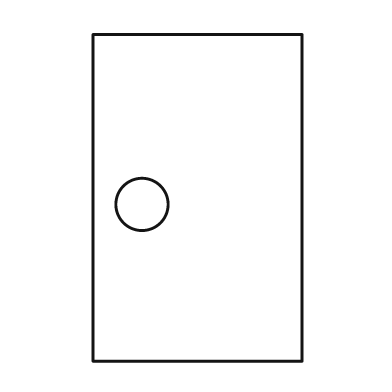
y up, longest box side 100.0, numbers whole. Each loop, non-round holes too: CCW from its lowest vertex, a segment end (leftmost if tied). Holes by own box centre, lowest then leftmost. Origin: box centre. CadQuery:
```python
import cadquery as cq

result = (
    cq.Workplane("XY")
    .moveTo(-32.0, -50.0)
    .lineTo(32.0, -50.0)
    .lineTo(32.0, 50.0)
    .lineTo(-32.0, 50.0)
    .close()
    .moveTo(-17.0, -2.0)
    .circle(8.0)
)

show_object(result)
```